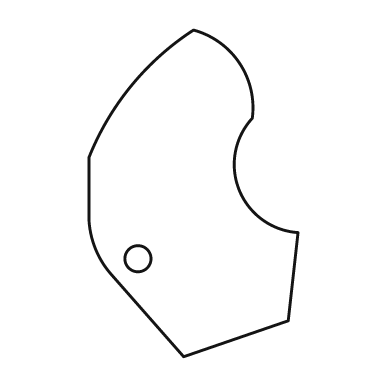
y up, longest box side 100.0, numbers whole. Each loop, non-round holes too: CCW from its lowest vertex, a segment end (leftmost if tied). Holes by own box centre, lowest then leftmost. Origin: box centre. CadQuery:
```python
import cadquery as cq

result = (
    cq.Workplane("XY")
    .moveTo(-3.0, -50.0)
    .lineTo(29.0, -39.0)
    .lineTo(32.0, -12.0)
    .threePointArc((14.0, 1.0), (18.0, 23.0))
    .threePointArc((14.0, 40.0), (0.0, 50.0))
    .threePointArc((-19.0, 33.0), (-32.0, 11.0))
    .lineTo(-32.0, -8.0)
    .threePointArc((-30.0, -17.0), (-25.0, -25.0))
    .close()
    .moveTo(-17.0, -20.0)
    .circle(4.0)
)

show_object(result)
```